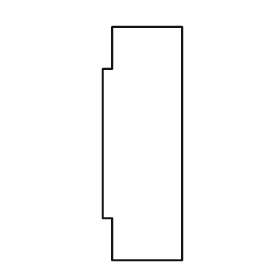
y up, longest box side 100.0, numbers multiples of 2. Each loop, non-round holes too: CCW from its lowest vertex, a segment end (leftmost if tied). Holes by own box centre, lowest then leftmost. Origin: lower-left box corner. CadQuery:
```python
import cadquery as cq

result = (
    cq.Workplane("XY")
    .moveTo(4.0, 0.0)
    .lineTo(34.0, 0.0)
    .lineTo(34.0, 100.0)
    .lineTo(4.0, 100.0)
    .lineTo(4.0, 82.0)
    .lineTo(0.0, 82.0)
    .lineTo(0.0, 18.0)
    .lineTo(4.0, 18.0)
    .close()
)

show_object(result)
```